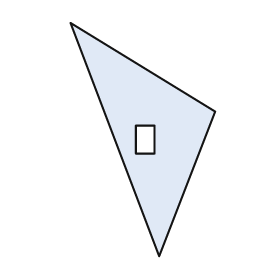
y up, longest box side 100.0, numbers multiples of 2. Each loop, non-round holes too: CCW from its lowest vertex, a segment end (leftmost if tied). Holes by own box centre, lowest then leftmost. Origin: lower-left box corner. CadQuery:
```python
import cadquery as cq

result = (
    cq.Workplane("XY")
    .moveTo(38.0, 0.0)
    .lineTo(62.0, 62.0)
    .lineTo(0.0, 100.0)
    .close()
    .moveTo(28.0, 44.0)
    .lineTo(36.0, 44.0)
    .lineTo(36.0, 56.0)
    .lineTo(28.0, 56.0)
    .close()
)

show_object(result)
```